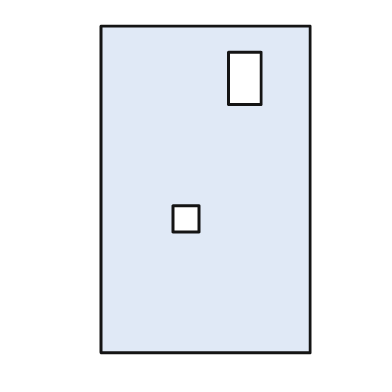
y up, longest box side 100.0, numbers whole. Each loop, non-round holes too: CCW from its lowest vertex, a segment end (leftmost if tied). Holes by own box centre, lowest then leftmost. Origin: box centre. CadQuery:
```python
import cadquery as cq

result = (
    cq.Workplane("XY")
    .moveTo(-32.0, -50.0)
    .lineTo(32.0, -50.0)
    .lineTo(32.0, 50.0)
    .lineTo(-32.0, 50.0)
    .close()
    .moveTo(-10.0, -13.0)
    .lineTo(-2.0, -13.0)
    .lineTo(-2.0, -5.0)
    .lineTo(-10.0, -5.0)
    .close()
    .moveTo(7.0, 26.0)
    .lineTo(17.0, 26.0)
    .lineTo(17.0, 42.0)
    .lineTo(7.0, 42.0)
    .close()
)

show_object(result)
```